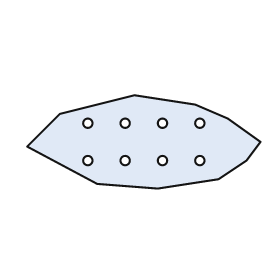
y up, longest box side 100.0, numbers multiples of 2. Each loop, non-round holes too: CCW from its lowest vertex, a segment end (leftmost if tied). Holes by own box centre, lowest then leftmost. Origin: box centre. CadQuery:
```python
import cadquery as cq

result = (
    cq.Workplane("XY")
    .moveTo(6.0, -20.0)
    .lineTo(32.0, -16.0)
    .lineTo(44.0, -8.0)
    .lineTo(50.0, 0.0)
    .lineTo(36.0, 10.0)
    .lineTo(22.0, 16.0)
    .lineTo(-4.0, 20.0)
    .lineTo(-36.0, 12.0)
    .lineTo(-50.0, -2.0)
    .lineTo(-20.0, -18.0)
    .close()
    .moveTo(-24.0, -8.0)
    .circle(2.0)
    .moveTo(-8.0, -8.0)
    .circle(2.0)
    .moveTo(8.0, -8.0)
    .circle(2.0)
    .moveTo(24.0, -8.0)
    .circle(2.0)
    .moveTo(-24.0, 8.0)
    .circle(2.0)
    .moveTo(-8.0, 8.0)
    .circle(2.0)
    .moveTo(8.0, 8.0)
    .circle(2.0)
    .moveTo(24.0, 8.0)
    .circle(2.0)
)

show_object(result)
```